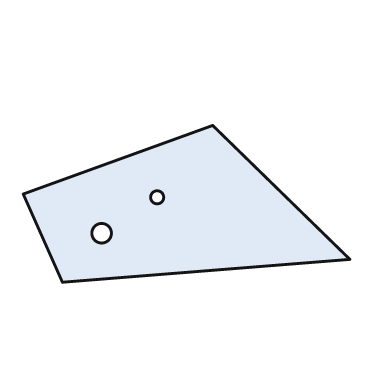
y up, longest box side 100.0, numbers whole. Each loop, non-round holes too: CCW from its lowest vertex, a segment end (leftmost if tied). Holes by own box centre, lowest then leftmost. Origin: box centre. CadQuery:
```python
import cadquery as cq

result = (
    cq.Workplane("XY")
    .moveTo(-38.0, -24.0)
    .lineTo(50.0, -17.0)
    .lineTo(8.0, 24.0)
    .lineTo(-50.0, 3.0)
    .close()
    .moveTo(-26.0, -9.0)
    .circle(3.0)
    .moveTo(-9.0, 2.0)
    .circle(2.0)
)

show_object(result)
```